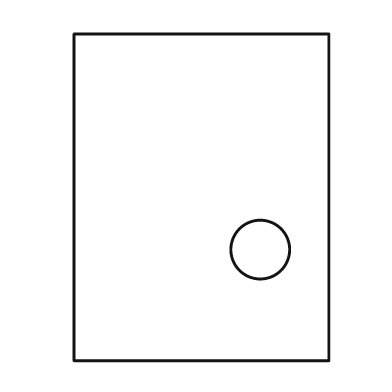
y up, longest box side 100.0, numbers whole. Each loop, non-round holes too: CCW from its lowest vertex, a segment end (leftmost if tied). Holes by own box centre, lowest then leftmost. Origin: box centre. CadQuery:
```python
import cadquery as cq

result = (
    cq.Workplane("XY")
    .moveTo(-39.0, -50.0)
    .lineTo(39.0, -50.0)
    .lineTo(39.0, 50.0)
    .lineTo(-39.0, 50.0)
    .close()
    .moveTo(18.0, -16.0)
    .circle(9.0)
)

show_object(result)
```